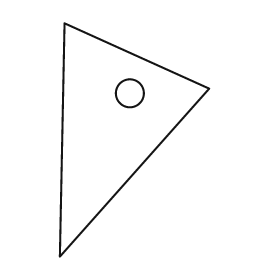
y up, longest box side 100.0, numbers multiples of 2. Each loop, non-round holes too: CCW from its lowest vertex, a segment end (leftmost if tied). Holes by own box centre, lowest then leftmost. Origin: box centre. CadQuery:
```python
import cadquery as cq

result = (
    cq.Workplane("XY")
    .moveTo(-32.0, -50.0)
    .lineTo(32.0, 22.0)
    .lineTo(-30.0, 50.0)
    .close()
    .moveTo(-2.0, 20.0)
    .circle(6.0)
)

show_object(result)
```